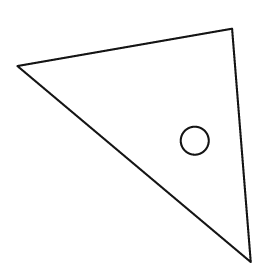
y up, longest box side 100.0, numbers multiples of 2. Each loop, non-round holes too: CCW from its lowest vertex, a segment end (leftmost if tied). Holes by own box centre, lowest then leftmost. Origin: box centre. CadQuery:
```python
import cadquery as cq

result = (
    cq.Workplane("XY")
    .moveTo(50.0, -50.0)
    .lineTo(42.0, 50.0)
    .lineTo(-50.0, 34.0)
    .close()
    .moveTo(26.0, 2.0)
    .circle(6.0)
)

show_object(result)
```